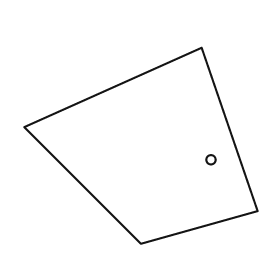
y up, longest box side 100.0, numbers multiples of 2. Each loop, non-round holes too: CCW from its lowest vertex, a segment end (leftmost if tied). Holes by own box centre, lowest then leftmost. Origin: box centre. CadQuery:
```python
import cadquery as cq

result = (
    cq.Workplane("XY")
    .moveTo(0.0, -42.0)
    .lineTo(50.0, -28.0)
    .lineTo(26.0, 42.0)
    .lineTo(-50.0, 8.0)
    .close()
    .moveTo(30.0, -6.0)
    .circle(2.0)
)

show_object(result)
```